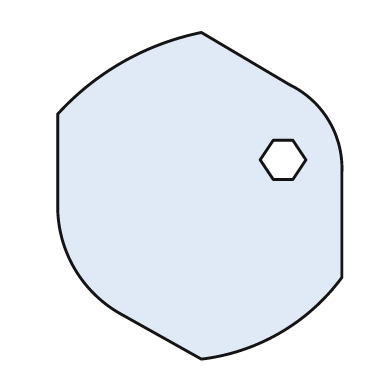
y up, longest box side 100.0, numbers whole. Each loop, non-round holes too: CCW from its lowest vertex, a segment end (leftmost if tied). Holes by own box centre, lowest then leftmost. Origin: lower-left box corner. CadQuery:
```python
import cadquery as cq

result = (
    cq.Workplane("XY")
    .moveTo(44.0, 0.0)
    .threePointArc((68.0, 8.0), (87.0, 25.0))
    .lineTo(87.0, 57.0)
    .threePointArc((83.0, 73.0), (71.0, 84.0))
    .lineTo(44.0, 100.0)
    .threePointArc((20.0, 91.0), (0.0, 75.0))
    .lineTo(0.0, 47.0)
    .threePointArc((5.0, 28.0), (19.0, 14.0))
    .close()
    .moveTo(66.0, 55.0)
    .lineTo(72.0, 55.0)
    .lineTo(76.0, 61.0)
    .lineTo(72.0, 67.0)
    .lineTo(66.0, 67.0)
    .lineTo(62.0, 61.0)
    .close()
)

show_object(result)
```